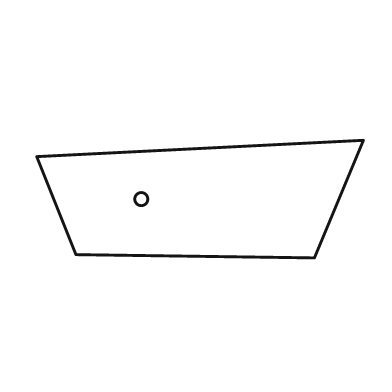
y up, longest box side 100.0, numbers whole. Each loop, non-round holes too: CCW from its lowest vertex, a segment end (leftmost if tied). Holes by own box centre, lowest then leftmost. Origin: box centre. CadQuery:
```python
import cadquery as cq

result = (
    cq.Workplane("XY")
    .moveTo(35.0, -18.0)
    .lineTo(50.0, 18.0)
    .lineTo(-50.0, 13.0)
    .lineTo(-38.0, -17.0)
    .close()
    .moveTo(-18.0, 0.0)
    .circle(2.0)
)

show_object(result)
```